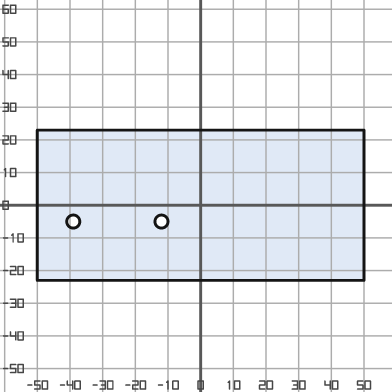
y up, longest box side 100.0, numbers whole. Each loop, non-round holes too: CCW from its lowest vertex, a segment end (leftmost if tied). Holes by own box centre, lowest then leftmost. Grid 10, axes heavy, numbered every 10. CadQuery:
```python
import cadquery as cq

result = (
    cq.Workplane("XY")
    .moveTo(-50.0, -23.0)
    .lineTo(50.0, -23.0)
    .lineTo(50.0, 23.0)
    .lineTo(-50.0, 23.0)
    .close()
    .moveTo(-39.0, -5.0)
    .circle(2.0)
    .moveTo(-12.0, -5.0)
    .circle(2.0)
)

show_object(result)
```